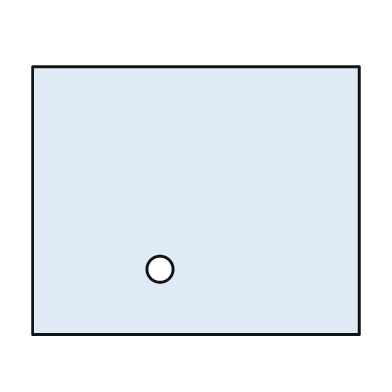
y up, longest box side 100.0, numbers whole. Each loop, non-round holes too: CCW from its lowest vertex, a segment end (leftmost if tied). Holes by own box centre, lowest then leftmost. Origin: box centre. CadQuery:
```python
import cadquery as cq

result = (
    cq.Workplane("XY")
    .moveTo(-50.0, -41.0)
    .lineTo(50.0, -41.0)
    .lineTo(50.0, 41.0)
    .lineTo(-50.0, 41.0)
    .close()
    .moveTo(-11.0, -21.0)
    .circle(4.0)
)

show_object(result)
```